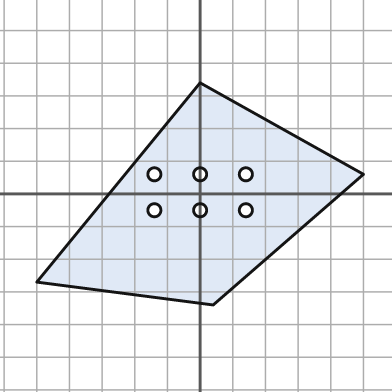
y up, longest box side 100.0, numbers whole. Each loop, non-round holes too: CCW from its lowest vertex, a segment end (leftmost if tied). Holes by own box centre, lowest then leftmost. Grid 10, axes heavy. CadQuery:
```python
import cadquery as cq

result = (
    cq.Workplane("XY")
    .moveTo(4.0, -34.0)
    .lineTo(50.0, 6.0)
    .lineTo(0.0, 34.0)
    .lineTo(-50.0, -27.0)
    .close()
    .moveTo(-14.0, -5.0)
    .circle(2.0)
    .moveTo(0.0, -5.0)
    .circle(2.0)
    .moveTo(14.0, -5.0)
    .circle(2.0)
    .moveTo(-14.0, 6.0)
    .circle(2.0)
    .moveTo(0.0, 6.0)
    .circle(2.0)
    .moveTo(14.0, 6.0)
    .circle(2.0)
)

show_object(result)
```